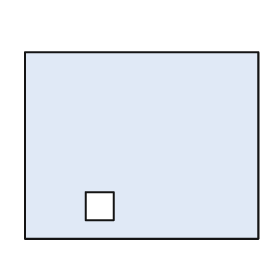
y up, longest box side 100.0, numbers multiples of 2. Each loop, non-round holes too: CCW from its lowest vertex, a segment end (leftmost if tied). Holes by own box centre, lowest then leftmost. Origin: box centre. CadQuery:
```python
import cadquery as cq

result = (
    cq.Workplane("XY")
    .moveTo(-50.0, -40.0)
    .lineTo(50.0, -40.0)
    .lineTo(50.0, 40.0)
    .lineTo(-50.0, 40.0)
    .close()
    .moveTo(-24.0, -32.0)
    .lineTo(-12.0, -32.0)
    .lineTo(-12.0, -20.0)
    .lineTo(-24.0, -20.0)
    .close()
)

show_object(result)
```